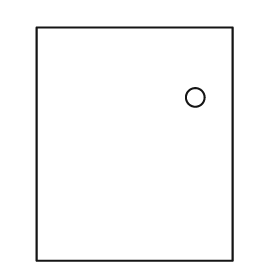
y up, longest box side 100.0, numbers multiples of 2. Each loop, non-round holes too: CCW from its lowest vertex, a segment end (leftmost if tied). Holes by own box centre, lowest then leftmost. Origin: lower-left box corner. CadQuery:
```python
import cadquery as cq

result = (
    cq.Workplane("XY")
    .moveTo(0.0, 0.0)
    .lineTo(84.0, 0.0)
    .lineTo(84.0, 100.0)
    .lineTo(0.0, 100.0)
    .close()
    .moveTo(68.0, 70.0)
    .circle(4.0)
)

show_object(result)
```